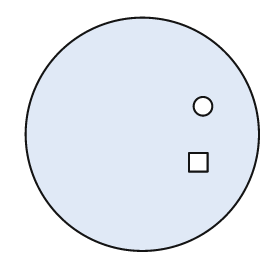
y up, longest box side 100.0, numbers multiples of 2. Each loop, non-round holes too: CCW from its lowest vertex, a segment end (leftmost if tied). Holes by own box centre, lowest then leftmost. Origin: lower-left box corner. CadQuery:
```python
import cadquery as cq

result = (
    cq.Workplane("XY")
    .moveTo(50.0, 50.0)
    .circle(50.0)
    .moveTo(70.0, 34.0)
    .lineTo(78.0, 34.0)
    .lineTo(78.0, 42.0)
    .lineTo(70.0, 42.0)
    .close()
    .moveTo(76.0, 62.0)
    .circle(4.0)
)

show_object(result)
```